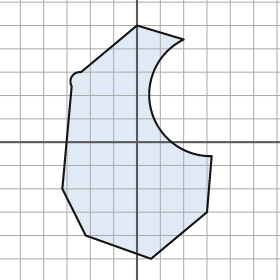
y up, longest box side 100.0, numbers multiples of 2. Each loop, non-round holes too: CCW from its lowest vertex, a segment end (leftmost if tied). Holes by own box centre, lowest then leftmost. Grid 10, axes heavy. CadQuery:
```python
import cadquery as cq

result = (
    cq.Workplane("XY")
    .moveTo(6.0, -50.0)
    .lineTo(30.0, -30.0)
    .lineTo(32.0, -6.0)
    .threePointArc((6.0, 14.0), (20.0, 44.0))
    .lineTo(0.0, 50.0)
    .lineTo(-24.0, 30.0)
    .threePointArc((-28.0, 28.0), (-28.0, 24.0))
    .lineTo(-32.0, -20.0)
    .lineTo(-22.0, -40.0)
    .close()
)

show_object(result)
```